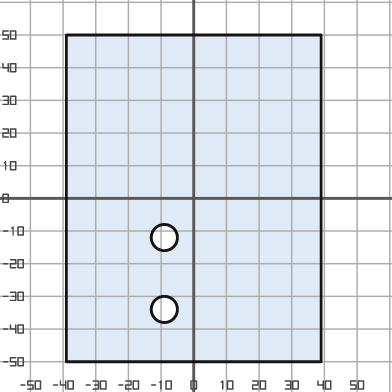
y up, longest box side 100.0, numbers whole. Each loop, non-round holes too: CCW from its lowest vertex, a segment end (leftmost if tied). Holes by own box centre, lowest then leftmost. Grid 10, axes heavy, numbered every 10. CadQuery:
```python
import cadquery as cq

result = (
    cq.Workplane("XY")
    .moveTo(-39.0, -50.0)
    .lineTo(39.0, -50.0)
    .lineTo(39.0, 50.0)
    .lineTo(-39.0, 50.0)
    .close()
    .moveTo(-9.0, -34.0)
    .circle(4.0)
    .moveTo(-9.0, -12.0)
    .circle(4.0)
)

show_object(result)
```